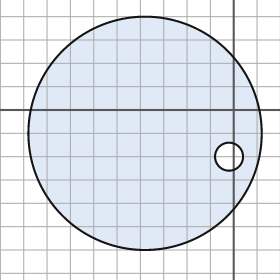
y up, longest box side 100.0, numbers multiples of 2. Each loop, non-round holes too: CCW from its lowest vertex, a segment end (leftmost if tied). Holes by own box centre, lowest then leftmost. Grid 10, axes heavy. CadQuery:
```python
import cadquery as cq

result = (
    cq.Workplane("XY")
    .moveTo(-38.0, -10.0)
    .circle(50.0)
    .moveTo(-2.0, -20.0)
    .circle(6.0)
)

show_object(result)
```